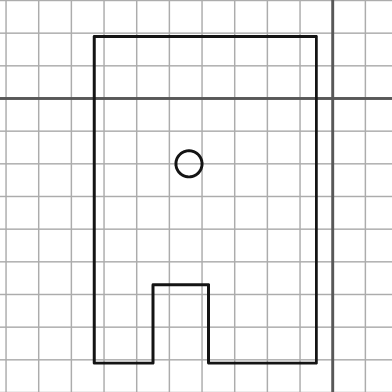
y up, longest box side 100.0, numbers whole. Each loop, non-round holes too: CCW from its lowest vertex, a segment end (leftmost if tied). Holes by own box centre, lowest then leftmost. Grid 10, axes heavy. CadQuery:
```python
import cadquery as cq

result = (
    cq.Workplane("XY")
    .moveTo(-73.0, -81.0)
    .lineTo(-55.0, -81.0)
    .lineTo(-55.0, -57.0)
    .lineTo(-38.0, -57.0)
    .lineTo(-38.0, -81.0)
    .lineTo(-5.0, -81.0)
    .lineTo(-5.0, 19.0)
    .lineTo(-73.0, 19.0)
    .close()
    .moveTo(-44.0, -20.0)
    .circle(4.0)
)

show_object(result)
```